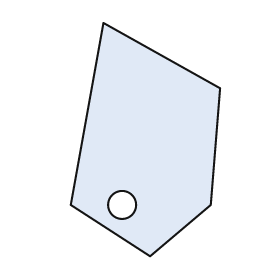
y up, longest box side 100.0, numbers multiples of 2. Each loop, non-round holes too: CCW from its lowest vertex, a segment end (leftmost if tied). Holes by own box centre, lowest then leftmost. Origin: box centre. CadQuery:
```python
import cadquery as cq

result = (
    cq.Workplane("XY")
    .moveTo(2.0, -50.0)
    .lineTo(28.0, -28.0)
    .lineTo(32.0, 22.0)
    .lineTo(-18.0, 50.0)
    .lineTo(-32.0, -28.0)
    .close()
    .moveTo(-10.0, -28.0)
    .circle(6.0)
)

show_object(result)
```